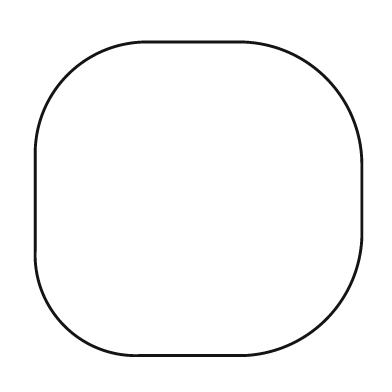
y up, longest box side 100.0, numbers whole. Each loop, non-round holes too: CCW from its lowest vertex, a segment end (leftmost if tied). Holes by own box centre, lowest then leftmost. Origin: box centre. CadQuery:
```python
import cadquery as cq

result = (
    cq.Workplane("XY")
    .moveTo(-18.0, -48.0)
    .lineTo(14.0, -48.0)
    .threePointArc((39.0, -37.0), (50.0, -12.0))
    .lineTo(50.0, 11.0)
    .threePointArc((39.0, 37.0), (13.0, 48.0))
    .lineTo(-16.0, 48.0)
    .threePointArc((-40.0, 38.0), (-50.0, 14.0))
    .lineTo(-50.0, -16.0)
    .threePointArc((-41.0, -39.0), (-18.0, -48.0))
    .close()
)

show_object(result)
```